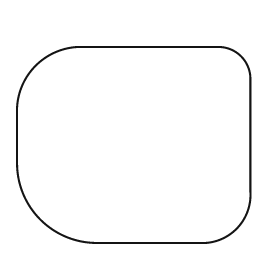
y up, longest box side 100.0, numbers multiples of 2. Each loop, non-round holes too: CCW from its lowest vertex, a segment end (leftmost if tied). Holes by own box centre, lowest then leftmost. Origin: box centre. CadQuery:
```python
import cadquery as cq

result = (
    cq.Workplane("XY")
    .moveTo(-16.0, -42.0)
    .lineTo(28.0, -42.0)
    .threePointArc((44.0, -36.0), (50.0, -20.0))
    .lineTo(50.0, 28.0)
    .threePointArc((46.0, 38.0), (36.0, 42.0))
    .lineTo(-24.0, 42.0)
    .threePointArc((-42.0, 34.0), (-50.0, 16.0))
    .lineTo(-50.0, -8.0)
    .threePointArc((-40.0, -32.0), (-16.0, -42.0))
    .close()
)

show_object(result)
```